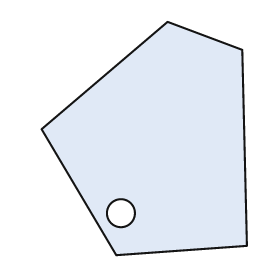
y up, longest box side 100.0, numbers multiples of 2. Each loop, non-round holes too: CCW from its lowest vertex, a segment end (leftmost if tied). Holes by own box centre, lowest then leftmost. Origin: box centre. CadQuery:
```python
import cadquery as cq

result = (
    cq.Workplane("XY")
    .moveTo(-12.0, -50.0)
    .lineTo(44.0, -46.0)
    .lineTo(42.0, 38.0)
    .lineTo(10.0, 50.0)
    .lineTo(-44.0, 4.0)
    .close()
    .moveTo(-10.0, -32.0)
    .circle(6.0)
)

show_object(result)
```